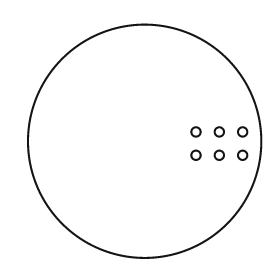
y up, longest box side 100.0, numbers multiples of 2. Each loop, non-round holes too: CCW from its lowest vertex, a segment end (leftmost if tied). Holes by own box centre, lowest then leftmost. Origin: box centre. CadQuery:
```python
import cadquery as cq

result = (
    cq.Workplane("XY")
    .moveTo(0.0, 0.0)
    .circle(50.0)
    .moveTo(22.0, -6.0)
    .circle(2.0)
    .moveTo(32.0, -6.0)
    .circle(2.0)
    .moveTo(42.0, -6.0)
    .circle(2.0)
    .moveTo(22.0, 4.0)
    .circle(2.0)
    .moveTo(32.0, 4.0)
    .circle(2.0)
    .moveTo(42.0, 4.0)
    .circle(2.0)
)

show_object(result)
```